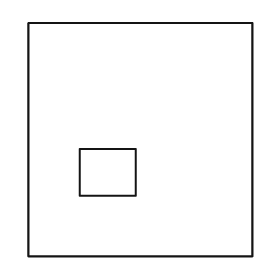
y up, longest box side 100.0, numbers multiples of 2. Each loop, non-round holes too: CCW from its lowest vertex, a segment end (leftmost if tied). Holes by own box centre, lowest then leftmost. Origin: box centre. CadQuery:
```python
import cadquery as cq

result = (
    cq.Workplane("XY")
    .moveTo(-48.0, -50.0)
    .lineTo(48.0, -50.0)
    .lineTo(48.0, 50.0)
    .lineTo(-48.0, 50.0)
    .close()
    .moveTo(-26.0, -24.0)
    .lineTo(-2.0, -24.0)
    .lineTo(-2.0, -4.0)
    .lineTo(-26.0, -4.0)
    .close()
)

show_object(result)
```